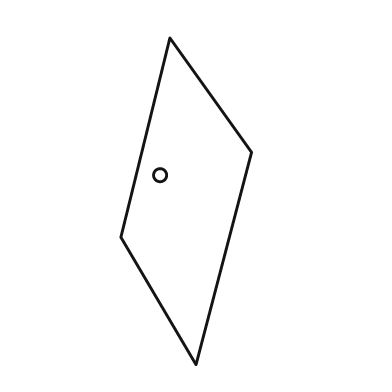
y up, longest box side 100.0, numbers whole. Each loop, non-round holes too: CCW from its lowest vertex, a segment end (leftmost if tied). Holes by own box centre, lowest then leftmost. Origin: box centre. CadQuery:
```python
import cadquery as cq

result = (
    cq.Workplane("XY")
    .moveTo(3.0, -50.0)
    .lineTo(20.0, 15.0)
    .lineTo(-5.0, 50.0)
    .lineTo(-20.0, -11.0)
    .close()
    .moveTo(-8.0, 8.0)
    .circle(2.0)
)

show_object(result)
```